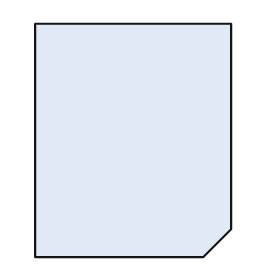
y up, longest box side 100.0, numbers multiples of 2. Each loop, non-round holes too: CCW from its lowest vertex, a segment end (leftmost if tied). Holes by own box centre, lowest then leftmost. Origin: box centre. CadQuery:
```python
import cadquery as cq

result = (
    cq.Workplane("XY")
    .moveTo(-42.0, -50.0)
    .lineTo(30.0, -50.0)
    .lineTo(42.0, -38.0)
    .lineTo(42.0, 50.0)
    .lineTo(-42.0, 50.0)
    .close()
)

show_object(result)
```